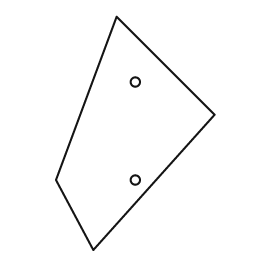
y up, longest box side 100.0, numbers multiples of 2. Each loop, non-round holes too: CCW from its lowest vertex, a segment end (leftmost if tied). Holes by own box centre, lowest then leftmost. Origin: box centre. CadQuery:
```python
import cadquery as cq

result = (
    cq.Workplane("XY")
    .moveTo(-18.0, -50.0)
    .lineTo(34.0, 8.0)
    .lineTo(-8.0, 50.0)
    .lineTo(-34.0, -20.0)
    .close()
    .moveTo(0.0, -20.0)
    .circle(2.0)
    .moveTo(0.0, 22.0)
    .circle(2.0)
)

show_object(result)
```